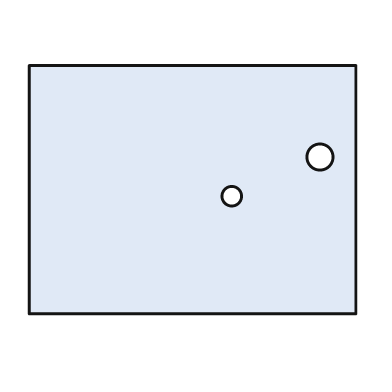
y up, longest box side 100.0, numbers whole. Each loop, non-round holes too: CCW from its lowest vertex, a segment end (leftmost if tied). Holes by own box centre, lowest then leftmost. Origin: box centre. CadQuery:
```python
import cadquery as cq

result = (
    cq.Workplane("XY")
    .moveTo(-50.0, -38.0)
    .lineTo(50.0, -38.0)
    .lineTo(50.0, 38.0)
    .lineTo(-50.0, 38.0)
    .close()
    .moveTo(12.0, -2.0)
    .circle(3.0)
    .moveTo(39.0, 10.0)
    .circle(4.0)
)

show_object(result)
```